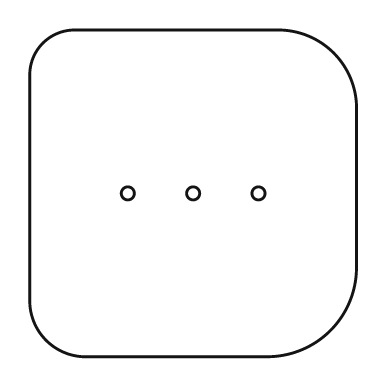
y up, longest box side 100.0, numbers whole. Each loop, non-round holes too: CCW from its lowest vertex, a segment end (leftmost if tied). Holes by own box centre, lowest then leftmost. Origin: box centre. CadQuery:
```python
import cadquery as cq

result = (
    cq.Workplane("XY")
    .moveTo(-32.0, -50.0)
    .lineTo(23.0, -50.0)
    .threePointArc((42.0, -42.0), (50.0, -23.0))
    .lineTo(50.0, 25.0)
    .threePointArc((43.0, 43.0), (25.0, 50.0))
    .lineTo(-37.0, 50.0)
    .threePointArc((-46.0, 46.0), (-50.0, 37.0))
    .lineTo(-50.0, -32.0)
    .threePointArc((-45.0, -45.0), (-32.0, -50.0))
    .close()
    .moveTo(-20.0, 0.0)
    .circle(2.0)
    .moveTo(0.0, 0.0)
    .circle(2.0)
    .moveTo(20.0, 0.0)
    .circle(2.0)
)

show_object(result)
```